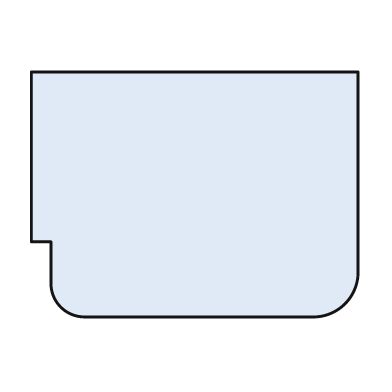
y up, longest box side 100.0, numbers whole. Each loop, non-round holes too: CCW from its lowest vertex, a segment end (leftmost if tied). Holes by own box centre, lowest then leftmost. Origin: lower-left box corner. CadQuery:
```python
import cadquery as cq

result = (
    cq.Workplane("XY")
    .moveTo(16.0, 0.0)
    .lineTo(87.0, 0.0)
    .threePointArc((96.0, 4.0), (100.0, 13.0))
    .lineTo(100.0, 75.0)
    .lineTo(0.0, 75.0)
    .lineTo(0.0, 23.0)
    .lineTo(6.0, 23.0)
    .lineTo(6.0, 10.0)
    .threePointArc((9.0, 3.0), (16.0, 0.0))
    .close()
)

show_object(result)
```